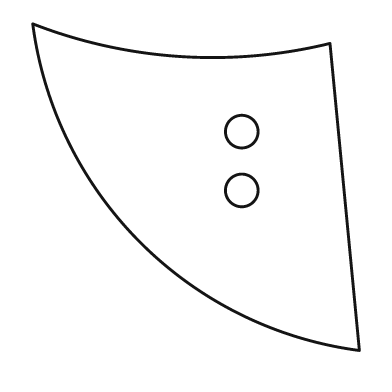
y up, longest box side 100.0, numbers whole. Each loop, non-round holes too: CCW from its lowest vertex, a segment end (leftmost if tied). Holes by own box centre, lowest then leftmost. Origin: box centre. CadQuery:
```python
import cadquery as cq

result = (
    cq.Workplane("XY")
    .moveTo(50.0, -50.0)
    .lineTo(41.0, 44.0)
    .threePointArc((-5.0, 40.0), (-50.0, 50.0))
    .threePointArc((-17.0, -17.0), (50.0, -50.0))
    .close()
    .moveTo(14.0, -1.0)
    .circle(5.0)
    .moveTo(14.0, 17.0)
    .circle(5.0)
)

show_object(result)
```